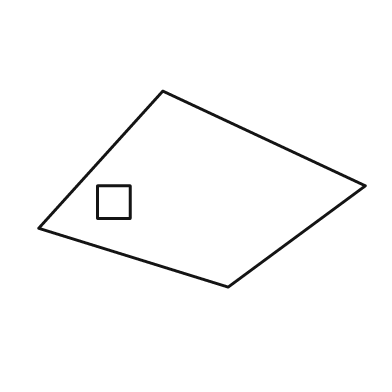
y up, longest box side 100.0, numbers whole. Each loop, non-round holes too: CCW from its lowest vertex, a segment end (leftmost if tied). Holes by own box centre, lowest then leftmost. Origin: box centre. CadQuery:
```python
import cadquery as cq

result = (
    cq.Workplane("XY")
    .moveTo(8.0, -30.0)
    .lineTo(50.0, 1.0)
    .lineTo(-12.0, 30.0)
    .lineTo(-50.0, -12.0)
    .close()
    .moveTo(-32.0, -9.0)
    .lineTo(-22.0, -9.0)
    .lineTo(-22.0, 1.0)
    .lineTo(-32.0, 1.0)
    .close()
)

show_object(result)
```